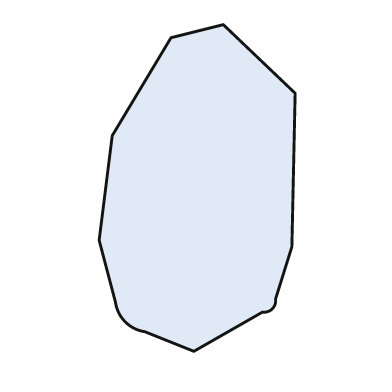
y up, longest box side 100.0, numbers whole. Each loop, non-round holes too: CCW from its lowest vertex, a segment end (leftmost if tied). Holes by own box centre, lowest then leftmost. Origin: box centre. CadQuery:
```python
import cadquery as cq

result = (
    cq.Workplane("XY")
    .moveTo(-1.0, -50.0)
    .lineTo(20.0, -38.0)
    .threePointArc((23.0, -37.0), (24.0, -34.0))
    .lineTo(29.0, -18.0)
    .lineTo(30.0, 29.0)
    .lineTo(8.0, 50.0)
    .lineTo(-8.0, 46.0)
    .lineTo(-26.0, 16.0)
    .lineTo(-30.0, -16.0)
    .lineTo(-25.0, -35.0)
    .threePointArc((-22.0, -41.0), (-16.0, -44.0))
    .close()
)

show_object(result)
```